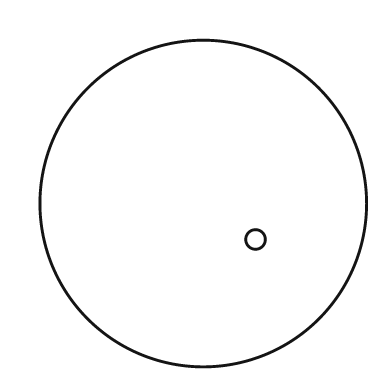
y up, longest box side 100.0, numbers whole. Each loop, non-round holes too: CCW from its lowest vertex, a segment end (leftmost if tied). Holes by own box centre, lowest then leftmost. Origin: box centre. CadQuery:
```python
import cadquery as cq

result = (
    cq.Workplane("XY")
    .moveTo(0.0, 0.0)
    .circle(50.0)
    .moveTo(16.0, -11.0)
    .circle(3.0)
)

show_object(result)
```